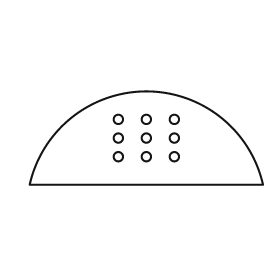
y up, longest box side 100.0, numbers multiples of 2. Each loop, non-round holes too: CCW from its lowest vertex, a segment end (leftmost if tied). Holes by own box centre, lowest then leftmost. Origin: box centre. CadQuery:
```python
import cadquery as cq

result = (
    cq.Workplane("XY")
    .moveTo(-50.0, -20.0)
    .lineTo(50.0, -20.0)
    .threePointArc((0.0, 20.0), (-50.0, -20.0))
    .close()
    .moveTo(-12.0, -8.0)
    .circle(2.0)
    .moveTo(0.0, -8.0)
    .circle(2.0)
    .moveTo(12.0, -8.0)
    .circle(2.0)
    .moveTo(-12.0, 0.0)
    .circle(2.0)
    .moveTo(0.0, 0.0)
    .circle(2.0)
    .moveTo(12.0, 0.0)
    .circle(2.0)
    .moveTo(-12.0, 8.0)
    .circle(2.0)
    .moveTo(0.0, 8.0)
    .circle(2.0)
    .moveTo(12.0, 8.0)
    .circle(2.0)
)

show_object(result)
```